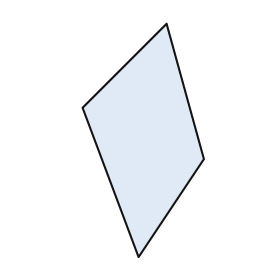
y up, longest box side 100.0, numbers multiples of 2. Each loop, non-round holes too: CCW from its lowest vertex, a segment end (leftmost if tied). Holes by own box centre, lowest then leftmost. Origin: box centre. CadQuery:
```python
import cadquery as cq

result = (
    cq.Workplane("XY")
    .moveTo(-2.0, -50.0)
    .lineTo(26.0, -8.0)
    .lineTo(10.0, 50.0)
    .lineTo(-26.0, 14.0)
    .close()
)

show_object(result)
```